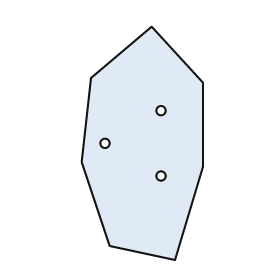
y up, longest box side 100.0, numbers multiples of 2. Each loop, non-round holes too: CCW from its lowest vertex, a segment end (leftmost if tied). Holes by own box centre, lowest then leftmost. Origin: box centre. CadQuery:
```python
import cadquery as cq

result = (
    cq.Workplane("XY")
    .moveTo(14.0, -50.0)
    .lineTo(26.0, -10.0)
    .lineTo(26.0, 26.0)
    .lineTo(4.0, 50.0)
    .lineTo(-22.0, 28.0)
    .lineTo(-26.0, -8.0)
    .lineTo(-14.0, -44.0)
    .close()
    .moveTo(8.0, -14.0)
    .circle(2.0)
    .moveTo(-16.0, 0.0)
    .circle(2.0)
    .moveTo(8.0, 14.0)
    .circle(2.0)
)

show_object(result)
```